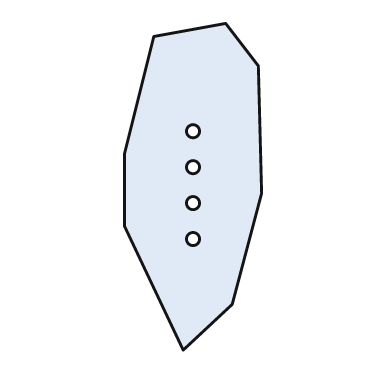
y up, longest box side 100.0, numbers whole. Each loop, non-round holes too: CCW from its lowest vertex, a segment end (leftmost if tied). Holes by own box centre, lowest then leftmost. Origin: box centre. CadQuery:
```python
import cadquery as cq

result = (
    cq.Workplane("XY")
    .moveTo(-3.0, -50.0)
    .lineTo(12.0, -36.0)
    .lineTo(21.0, -2.0)
    .lineTo(20.0, 37.0)
    .lineTo(10.0, 50.0)
    .lineTo(-12.0, 46.0)
    .lineTo(-21.0, 10.0)
    .lineTo(-21.0, -12.0)
    .close()
    .moveTo(0.0, -16.0)
    .circle(2.0)
    .moveTo(0.0, -5.0)
    .circle(2.0)
    .moveTo(0.0, 6.0)
    .circle(2.0)
    .moveTo(0.0, 17.0)
    .circle(2.0)
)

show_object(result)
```